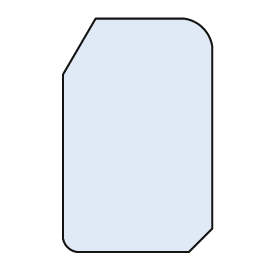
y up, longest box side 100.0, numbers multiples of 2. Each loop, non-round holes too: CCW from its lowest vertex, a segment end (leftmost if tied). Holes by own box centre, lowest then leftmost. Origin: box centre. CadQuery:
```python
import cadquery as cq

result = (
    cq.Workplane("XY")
    .moveTo(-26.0, -50.0)
    .lineTo(22.0, -50.0)
    .lineTo(32.0, -40.0)
    .lineTo(32.0, 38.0)
    .threePointArc((28.0, 46.0), (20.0, 50.0))
    .lineTo(-18.0, 50.0)
    .lineTo(-32.0, 26.0)
    .lineTo(-32.0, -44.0)
    .threePointArc((-30.0, -48.0), (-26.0, -50.0))
    .close()
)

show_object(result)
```